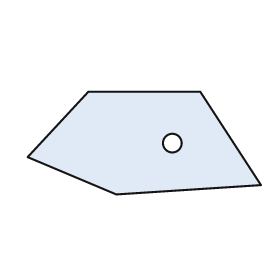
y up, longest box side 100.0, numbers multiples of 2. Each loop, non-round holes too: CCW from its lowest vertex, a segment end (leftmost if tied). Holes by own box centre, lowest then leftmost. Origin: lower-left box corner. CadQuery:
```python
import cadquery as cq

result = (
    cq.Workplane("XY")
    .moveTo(38.0, 0.0)
    .lineTo(100.0, 4.0)
    .lineTo(74.0, 44.0)
    .lineTo(26.0, 44.0)
    .lineTo(0.0, 16.0)
    .close()
    .moveTo(62.0, 22.0)
    .circle(4.0)
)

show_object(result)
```